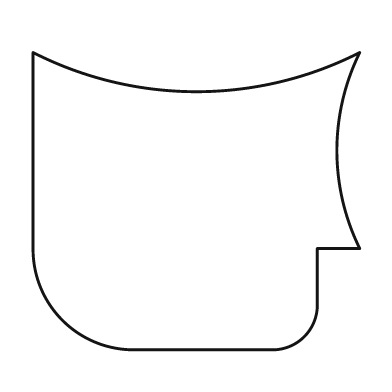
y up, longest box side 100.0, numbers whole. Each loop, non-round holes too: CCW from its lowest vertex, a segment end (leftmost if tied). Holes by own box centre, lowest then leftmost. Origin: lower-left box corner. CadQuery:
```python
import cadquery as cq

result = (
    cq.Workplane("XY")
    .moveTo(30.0, 0.0)
    .lineTo(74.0, 0.0)
    .threePointArc((83.0, 4.0), (87.0, 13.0))
    .lineTo(87.0, 31.0)
    .lineTo(100.0, 31.0)
    .threePointArc((93.0, 61.0), (100.0, 91.0))
    .threePointArc((50.0, 79.0), (0.0, 91.0))
    .lineTo(0.0, 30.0)
    .threePointArc((9.0, 9.0), (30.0, 0.0))
    .close()
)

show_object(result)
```